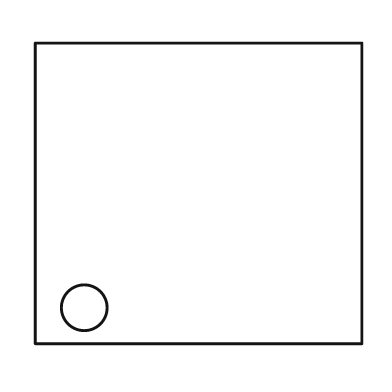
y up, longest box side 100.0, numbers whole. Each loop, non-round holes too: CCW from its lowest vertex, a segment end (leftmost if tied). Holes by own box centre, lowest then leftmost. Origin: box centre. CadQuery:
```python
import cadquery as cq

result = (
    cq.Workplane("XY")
    .moveTo(-50.0, -46.0)
    .lineTo(50.0, -46.0)
    .lineTo(50.0, 46.0)
    .lineTo(-50.0, 46.0)
    .close()
    .moveTo(-35.0, -35.0)
    .circle(7.0)
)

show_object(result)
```